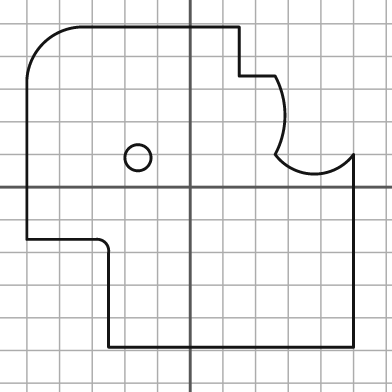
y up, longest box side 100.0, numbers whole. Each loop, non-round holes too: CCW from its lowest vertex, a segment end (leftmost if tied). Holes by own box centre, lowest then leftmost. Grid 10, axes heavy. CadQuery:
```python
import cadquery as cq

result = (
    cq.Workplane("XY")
    .moveTo(-25.0, -49.0)
    .lineTo(50.0, -49.0)
    .lineTo(50.0, 10.0)
    .threePointArc((38.0, 4.0), (26.0, 10.0))
    .threePointArc((29.0, 22.0), (26.0, 34.0))
    .lineTo(15.0, 34.0)
    .lineTo(15.0, 49.0)
    .lineTo(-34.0, 49.0)
    .threePointArc((-45.0, 44.0), (-50.0, 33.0))
    .lineTo(-50.0, -16.0)
    .lineTo(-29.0, -16.0)
    .threePointArc((-26.0, -17.0), (-25.0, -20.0))
    .close()
    .moveTo(-16.0, 9.0)
    .circle(4.0)
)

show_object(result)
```